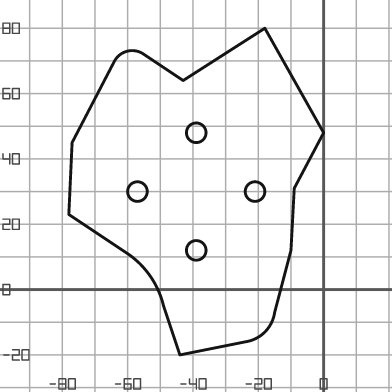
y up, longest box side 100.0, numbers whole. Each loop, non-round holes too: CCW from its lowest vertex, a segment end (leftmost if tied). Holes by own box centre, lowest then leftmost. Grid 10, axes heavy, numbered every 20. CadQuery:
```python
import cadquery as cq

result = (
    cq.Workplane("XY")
    .moveTo(-44.0, -20.0)
    .lineTo(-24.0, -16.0)
    .threePointArc((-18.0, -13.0), (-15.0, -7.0))
    .lineTo(-10.0, 12.0)
    .lineTo(-9.0, 31.0)
    .lineTo(0.0, 48.0)
    .lineTo(-18.0, 80.0)
    .lineTo(-43.0, 64.0)
    .lineTo(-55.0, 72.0)
    .threePointArc((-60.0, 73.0), (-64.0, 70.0))
    .lineTo(-77.0, 45.0)
    .lineTo(-78.0, 23.0)
    .lineTo(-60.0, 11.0)
    .threePointArc((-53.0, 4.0), (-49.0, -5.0))
    .close()
    .moveTo(-39.0, 12.0)
    .circle(3.0)
    .moveTo(-57.0, 30.0)
    .circle(3.0)
    .moveTo(-21.0, 30.0)
    .circle(3.0)
    .moveTo(-39.0, 48.0)
    .circle(3.0)
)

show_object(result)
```